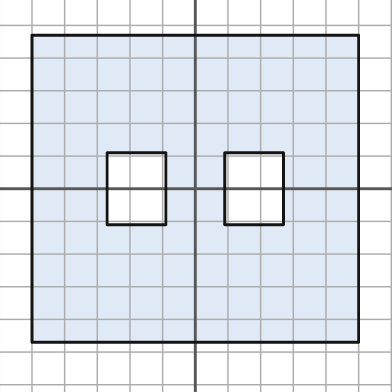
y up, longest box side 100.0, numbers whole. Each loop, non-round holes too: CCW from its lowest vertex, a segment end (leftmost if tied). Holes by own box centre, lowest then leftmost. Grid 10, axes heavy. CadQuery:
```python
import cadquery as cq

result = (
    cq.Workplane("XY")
    .moveTo(-50.0, -47.0)
    .lineTo(50.0, -47.0)
    .lineTo(50.0, 47.0)
    .lineTo(-50.0, 47.0)
    .close()
    .moveTo(-27.0, -11.0)
    .lineTo(-9.0, -11.0)
    .lineTo(-9.0, 11.0)
    .lineTo(-27.0, 11.0)
    .close()
    .moveTo(9.0, -11.0)
    .lineTo(27.0, -11.0)
    .lineTo(27.0, 11.0)
    .lineTo(9.0, 11.0)
    .close()
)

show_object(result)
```